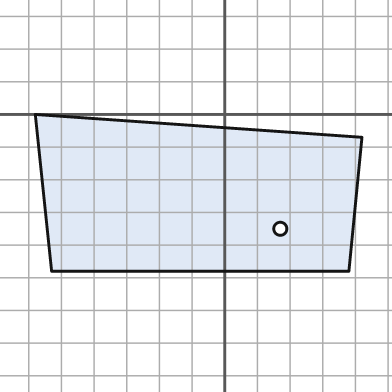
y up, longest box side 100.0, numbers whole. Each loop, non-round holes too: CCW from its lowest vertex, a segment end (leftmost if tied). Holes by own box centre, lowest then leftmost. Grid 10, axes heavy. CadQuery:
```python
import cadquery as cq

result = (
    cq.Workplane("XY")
    .moveTo(-53.0, -48.0)
    .lineTo(38.0, -48.0)
    .lineTo(42.0, -7.0)
    .lineTo(-58.0, 0.0)
    .close()
    .moveTo(17.0, -35.0)
    .circle(2.0)
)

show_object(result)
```